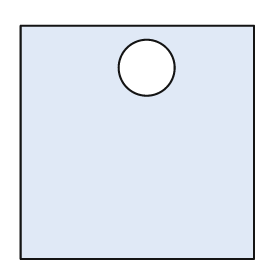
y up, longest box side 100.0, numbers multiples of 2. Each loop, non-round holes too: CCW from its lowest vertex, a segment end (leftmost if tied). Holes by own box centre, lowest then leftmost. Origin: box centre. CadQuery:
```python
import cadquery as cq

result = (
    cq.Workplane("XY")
    .moveTo(-50.0, -50.0)
    .lineTo(50.0, -50.0)
    .lineTo(50.0, 50.0)
    .lineTo(-50.0, 50.0)
    .close()
    .moveTo(4.0, 32.0)
    .circle(12.0)
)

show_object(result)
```